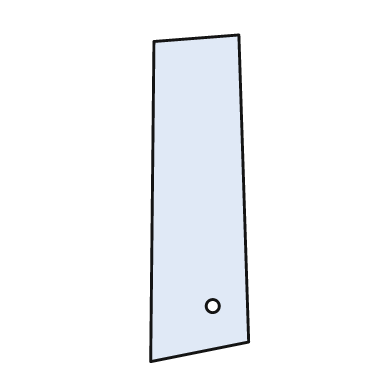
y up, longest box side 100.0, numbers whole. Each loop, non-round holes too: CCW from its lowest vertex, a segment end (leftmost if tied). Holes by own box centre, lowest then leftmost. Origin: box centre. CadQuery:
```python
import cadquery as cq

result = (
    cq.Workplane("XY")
    .moveTo(-15.0, -50.0)
    .lineTo(15.0, -44.0)
    .lineTo(12.0, 50.0)
    .lineTo(-14.0, 48.0)
    .close()
    .moveTo(4.0, -33.0)
    .circle(2.0)
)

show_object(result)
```